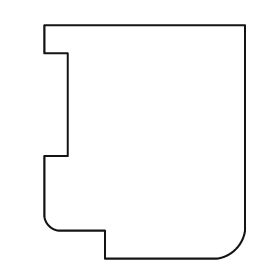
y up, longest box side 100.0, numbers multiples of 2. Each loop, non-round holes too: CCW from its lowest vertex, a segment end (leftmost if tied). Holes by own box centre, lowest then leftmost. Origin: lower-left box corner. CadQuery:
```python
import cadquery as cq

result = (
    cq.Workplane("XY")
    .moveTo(26.0, 0.0)
    .lineTo(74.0, 0.0)
    .threePointArc((82.0, 4.0), (86.0, 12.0))
    .lineTo(86.0, 100.0)
    .lineTo(0.0, 100.0)
    .lineTo(0.0, 88.0)
    .lineTo(10.0, 88.0)
    .lineTo(10.0, 44.0)
    .lineTo(0.0, 44.0)
    .lineTo(0.0, 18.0)
    .threePointArc((2.0, 14.0), (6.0, 12.0))
    .lineTo(26.0, 12.0)
    .close()
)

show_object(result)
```